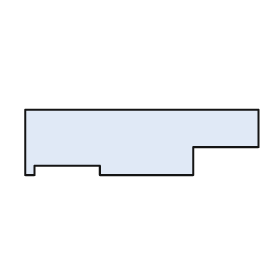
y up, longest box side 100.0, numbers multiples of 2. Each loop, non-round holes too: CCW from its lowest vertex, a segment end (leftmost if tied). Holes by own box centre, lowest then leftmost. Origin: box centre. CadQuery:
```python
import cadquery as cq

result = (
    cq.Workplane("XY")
    .moveTo(-50.0, -14.0)
    .lineTo(-46.0, -14.0)
    .lineTo(-46.0, -10.0)
    .lineTo(-18.0, -10.0)
    .lineTo(-18.0, -14.0)
    .lineTo(22.0, -14.0)
    .lineTo(22.0, -2.0)
    .lineTo(50.0, -2.0)
    .lineTo(50.0, 14.0)
    .lineTo(-50.0, 14.0)
    .close()
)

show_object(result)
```